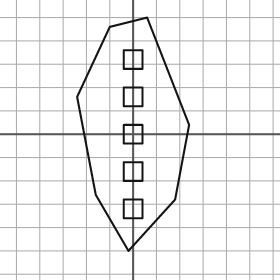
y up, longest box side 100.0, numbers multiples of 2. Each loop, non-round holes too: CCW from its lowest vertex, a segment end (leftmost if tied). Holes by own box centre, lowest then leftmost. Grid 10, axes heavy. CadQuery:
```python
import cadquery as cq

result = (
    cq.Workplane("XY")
    .moveTo(-2.0, -50.0)
    .lineTo(18.0, -28.0)
    .lineTo(24.0, 4.0)
    .lineTo(6.0, 50.0)
    .lineTo(-10.0, 46.0)
    .lineTo(-24.0, 16.0)
    .lineTo(-16.0, -26.0)
    .close()
    .moveTo(-4.0, -36.0)
    .lineTo(4.0, -36.0)
    .lineTo(4.0, -28.0)
    .lineTo(-4.0, -28.0)
    .close()
    .moveTo(-4.0, -20.0)
    .lineTo(4.0, -20.0)
    .lineTo(4.0, -12.0)
    .lineTo(-4.0, -12.0)
    .close()
    .moveTo(-4.0, -4.0)
    .lineTo(4.0, -4.0)
    .lineTo(4.0, 4.0)
    .lineTo(-4.0, 4.0)
    .close()
    .moveTo(-4.0, 12.0)
    .lineTo(4.0, 12.0)
    .lineTo(4.0, 20.0)
    .lineTo(-4.0, 20.0)
    .close()
    .moveTo(-4.0, 28.0)
    .lineTo(4.0, 28.0)
    .lineTo(4.0, 36.0)
    .lineTo(-4.0, 36.0)
    .close()
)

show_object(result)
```